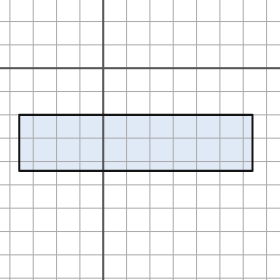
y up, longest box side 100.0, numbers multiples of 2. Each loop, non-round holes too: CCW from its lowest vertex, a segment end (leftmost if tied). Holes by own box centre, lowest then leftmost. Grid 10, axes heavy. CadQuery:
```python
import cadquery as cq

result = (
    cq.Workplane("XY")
    .moveTo(-36.0, -44.0)
    .lineTo(64.0, -44.0)
    .lineTo(64.0, -20.0)
    .lineTo(-36.0, -20.0)
    .close()
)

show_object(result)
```